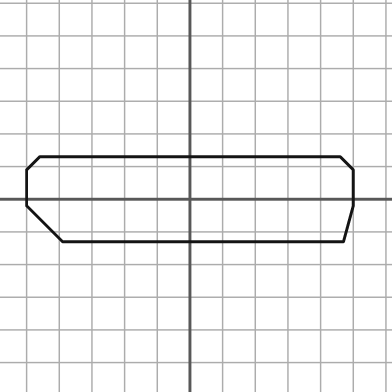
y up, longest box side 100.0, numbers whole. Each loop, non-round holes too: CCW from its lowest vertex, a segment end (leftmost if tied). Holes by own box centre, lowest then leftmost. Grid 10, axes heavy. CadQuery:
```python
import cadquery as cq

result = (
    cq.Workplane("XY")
    .moveTo(-39.0, -13.0)
    .lineTo(47.0, -13.0)
    .lineTo(50.0, -2.0)
    .lineTo(50.0, 9.0)
    .lineTo(46.0, 13.0)
    .lineTo(-46.0, 13.0)
    .lineTo(-50.0, 9.0)
    .lineTo(-50.0, -2.0)
    .close()
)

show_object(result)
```